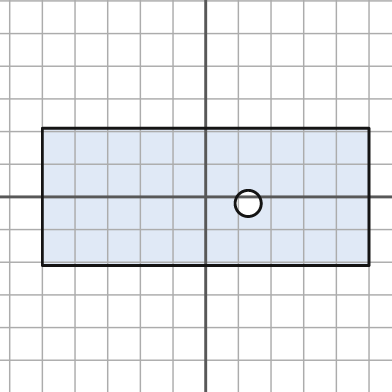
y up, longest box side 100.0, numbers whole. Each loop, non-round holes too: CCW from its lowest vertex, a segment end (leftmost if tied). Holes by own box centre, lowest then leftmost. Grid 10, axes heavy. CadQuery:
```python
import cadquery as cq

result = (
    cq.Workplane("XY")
    .moveTo(-50.0, -21.0)
    .lineTo(50.0, -21.0)
    .lineTo(50.0, 21.0)
    .lineTo(-50.0, 21.0)
    .close()
    .moveTo(13.0, -2.0)
    .circle(4.0)
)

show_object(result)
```